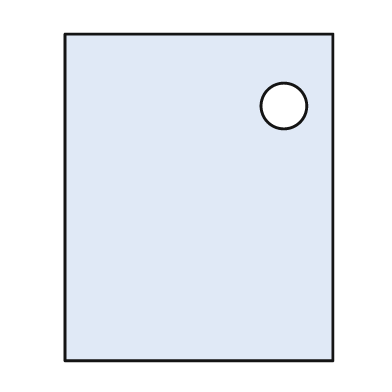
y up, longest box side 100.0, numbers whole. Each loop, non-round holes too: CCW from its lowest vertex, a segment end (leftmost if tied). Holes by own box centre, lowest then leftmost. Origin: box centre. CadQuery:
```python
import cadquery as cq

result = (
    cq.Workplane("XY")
    .moveTo(-41.0, -50.0)
    .lineTo(41.0, -50.0)
    .lineTo(41.0, 50.0)
    .lineTo(-41.0, 50.0)
    .close()
    .moveTo(26.0, 28.0)
    .circle(7.0)
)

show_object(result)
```